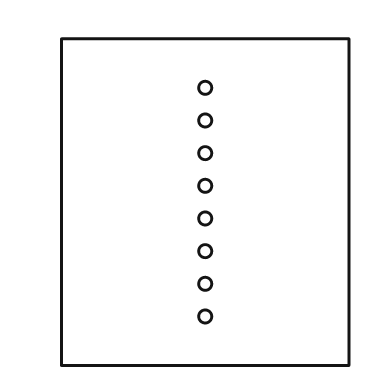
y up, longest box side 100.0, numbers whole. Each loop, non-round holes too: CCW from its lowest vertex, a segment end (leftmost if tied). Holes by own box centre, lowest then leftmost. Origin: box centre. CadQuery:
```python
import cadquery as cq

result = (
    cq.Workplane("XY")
    .moveTo(-44.0, -50.0)
    .lineTo(44.0, -50.0)
    .lineTo(44.0, 50.0)
    .lineTo(-44.0, 50.0)
    .close()
    .moveTo(0.0, -35.0)
    .circle(2.0)
    .moveTo(0.0, -25.0)
    .circle(2.0)
    .moveTo(0.0, -15.0)
    .circle(2.0)
    .moveTo(0.0, -5.0)
    .circle(2.0)
    .moveTo(0.0, 5.0)
    .circle(2.0)
    .moveTo(0.0, 15.0)
    .circle(2.0)
    .moveTo(0.0, 25.0)
    .circle(2.0)
    .moveTo(0.0, 35.0)
    .circle(2.0)
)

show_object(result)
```